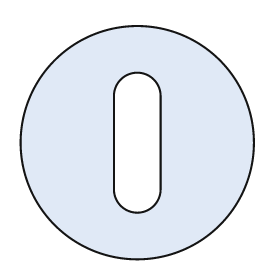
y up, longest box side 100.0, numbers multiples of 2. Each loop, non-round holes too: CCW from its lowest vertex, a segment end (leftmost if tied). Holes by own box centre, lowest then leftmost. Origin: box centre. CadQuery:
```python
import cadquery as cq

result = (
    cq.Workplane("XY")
    .moveTo(0.0, 0.0)
    .circle(50.0)
    .moveTo(-10.0, -20.0)
    .threePointArc((0.0, -30.0), (10.0, -20.0))
    .lineTo(10.0, 20.0)
    .threePointArc((0.0, 30.0), (-10.0, 20.0))
    .close()
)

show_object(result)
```